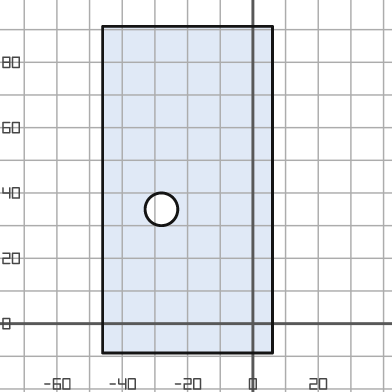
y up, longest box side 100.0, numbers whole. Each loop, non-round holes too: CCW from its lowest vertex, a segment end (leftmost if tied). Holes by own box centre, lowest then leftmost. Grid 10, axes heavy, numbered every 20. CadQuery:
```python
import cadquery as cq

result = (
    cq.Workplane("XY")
    .moveTo(-46.0, -9.0)
    .lineTo(6.0, -9.0)
    .lineTo(6.0, 91.0)
    .lineTo(-46.0, 91.0)
    .close()
    .moveTo(-28.0, 35.0)
    .circle(5.0)
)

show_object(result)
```